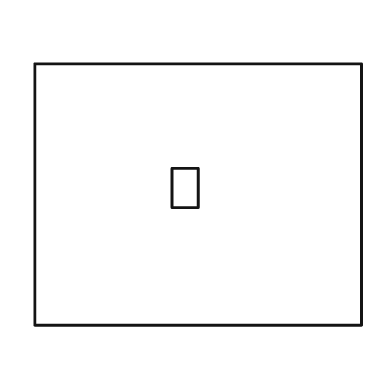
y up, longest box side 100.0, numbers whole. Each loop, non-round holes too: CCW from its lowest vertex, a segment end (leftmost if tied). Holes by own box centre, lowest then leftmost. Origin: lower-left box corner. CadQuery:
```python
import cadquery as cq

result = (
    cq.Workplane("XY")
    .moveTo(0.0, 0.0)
    .lineTo(100.0, 0.0)
    .lineTo(100.0, 80.0)
    .lineTo(0.0, 80.0)
    .close()
    .moveTo(42.0, 36.0)
    .lineTo(50.0, 36.0)
    .lineTo(50.0, 48.0)
    .lineTo(42.0, 48.0)
    .close()
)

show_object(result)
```